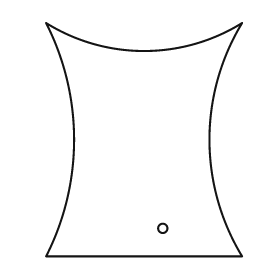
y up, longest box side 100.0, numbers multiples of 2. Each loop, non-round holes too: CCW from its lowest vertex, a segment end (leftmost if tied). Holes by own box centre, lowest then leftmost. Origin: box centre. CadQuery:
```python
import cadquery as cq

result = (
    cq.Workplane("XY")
    .moveTo(-42.0, -50.0)
    .lineTo(42.0, -50.0)
    .threePointArc((28.0, 0.0), (42.0, 50.0))
    .threePointArc((0.0, 38.0), (-42.0, 50.0))
    .threePointArc((-30.0, 0.0), (-42.0, -50.0))
    .close()
    .moveTo(8.0, -38.0)
    .circle(2.0)
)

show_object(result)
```